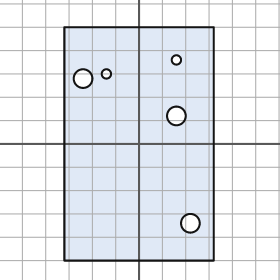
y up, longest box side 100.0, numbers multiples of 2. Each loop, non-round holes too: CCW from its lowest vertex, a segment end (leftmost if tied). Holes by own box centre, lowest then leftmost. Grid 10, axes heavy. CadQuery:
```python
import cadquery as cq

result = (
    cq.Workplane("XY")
    .moveTo(-32.0, -50.0)
    .lineTo(32.0, -50.0)
    .lineTo(32.0, 50.0)
    .lineTo(-32.0, 50.0)
    .close()
    .moveTo(22.0, -34.0)
    .circle(4.0)
    .moveTo(16.0, 12.0)
    .circle(4.0)
    .moveTo(-24.0, 28.0)
    .circle(4.0)
    .moveTo(-14.0, 30.0)
    .circle(2.0)
    .moveTo(16.0, 36.0)
    .circle(2.0)
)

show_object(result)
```